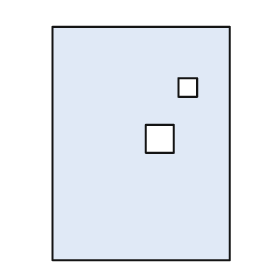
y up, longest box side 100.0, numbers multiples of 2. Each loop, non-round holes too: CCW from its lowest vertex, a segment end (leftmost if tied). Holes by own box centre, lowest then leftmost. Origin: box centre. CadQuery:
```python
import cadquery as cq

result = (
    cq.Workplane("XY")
    .moveTo(-38.0, -50.0)
    .lineTo(38.0, -50.0)
    .lineTo(38.0, 50.0)
    .lineTo(-38.0, 50.0)
    .close()
    .moveTo(2.0, -4.0)
    .lineTo(14.0, -4.0)
    .lineTo(14.0, 8.0)
    .lineTo(2.0, 8.0)
    .close()
    .moveTo(16.0, 20.0)
    .lineTo(24.0, 20.0)
    .lineTo(24.0, 28.0)
    .lineTo(16.0, 28.0)
    .close()
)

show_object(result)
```